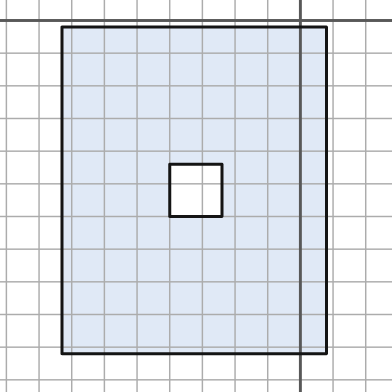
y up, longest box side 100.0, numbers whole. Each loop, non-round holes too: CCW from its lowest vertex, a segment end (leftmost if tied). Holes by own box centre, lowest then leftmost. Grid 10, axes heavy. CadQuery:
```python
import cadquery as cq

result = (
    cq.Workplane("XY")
    .moveTo(-73.0, -102.0)
    .lineTo(8.0, -102.0)
    .lineTo(8.0, -2.0)
    .lineTo(-73.0, -2.0)
    .close()
    .moveTo(-40.0, -60.0)
    .lineTo(-24.0, -60.0)
    .lineTo(-24.0, -44.0)
    .lineTo(-40.0, -44.0)
    .close()
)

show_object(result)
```